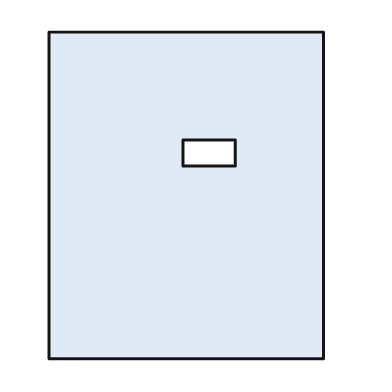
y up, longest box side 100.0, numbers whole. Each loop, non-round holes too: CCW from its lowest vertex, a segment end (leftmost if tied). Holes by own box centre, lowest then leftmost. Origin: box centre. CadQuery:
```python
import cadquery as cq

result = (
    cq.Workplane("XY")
    .moveTo(-42.0, -50.0)
    .lineTo(42.0, -50.0)
    .lineTo(42.0, 50.0)
    .lineTo(-42.0, 50.0)
    .close()
    .moveTo(-1.0, 9.0)
    .lineTo(15.0, 9.0)
    .lineTo(15.0, 17.0)
    .lineTo(-1.0, 17.0)
    .close()
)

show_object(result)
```